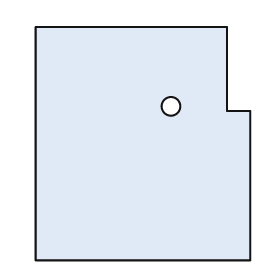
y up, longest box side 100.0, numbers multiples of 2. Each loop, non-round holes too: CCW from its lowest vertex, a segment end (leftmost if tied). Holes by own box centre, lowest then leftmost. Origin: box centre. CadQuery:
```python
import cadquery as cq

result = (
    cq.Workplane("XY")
    .moveTo(-46.0, -50.0)
    .lineTo(46.0, -50.0)
    .lineTo(46.0, 14.0)
    .lineTo(36.0, 14.0)
    .lineTo(36.0, 50.0)
    .lineTo(-46.0, 50.0)
    .close()
    .moveTo(12.0, 16.0)
    .circle(4.0)
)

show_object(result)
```